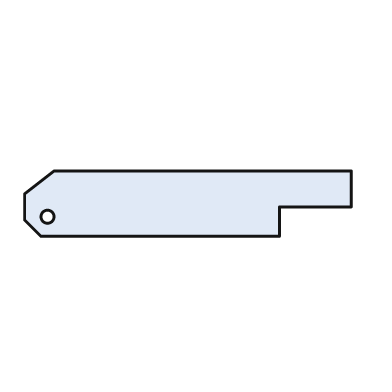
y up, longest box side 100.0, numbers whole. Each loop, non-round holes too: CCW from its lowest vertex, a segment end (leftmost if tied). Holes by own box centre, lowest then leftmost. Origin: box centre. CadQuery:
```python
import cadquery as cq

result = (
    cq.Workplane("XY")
    .moveTo(-45.0, -10.0)
    .lineTo(28.0, -10.0)
    .lineTo(28.0, -1.0)
    .lineTo(50.0, -1.0)
    .lineTo(50.0, 10.0)
    .lineTo(-41.0, 10.0)
    .lineTo(-50.0, 3.0)
    .lineTo(-50.0, -5.0)
    .close()
    .moveTo(-43.0, -4.0)
    .circle(2.0)
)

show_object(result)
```